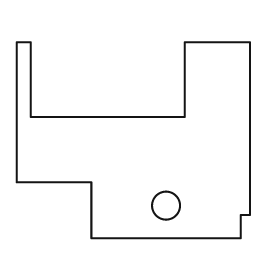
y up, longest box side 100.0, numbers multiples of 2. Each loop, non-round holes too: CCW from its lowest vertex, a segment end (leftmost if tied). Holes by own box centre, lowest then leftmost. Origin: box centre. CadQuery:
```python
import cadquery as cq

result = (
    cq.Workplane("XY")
    .moveTo(-18.0, -42.0)
    .lineTo(46.0, -42.0)
    .lineTo(46.0, -32.0)
    .lineTo(50.0, -32.0)
    .lineTo(50.0, 42.0)
    .lineTo(22.0, 42.0)
    .lineTo(22.0, 10.0)
    .lineTo(-44.0, 10.0)
    .lineTo(-44.0, 42.0)
    .lineTo(-50.0, 42.0)
    .lineTo(-50.0, -18.0)
    .lineTo(-18.0, -18.0)
    .close()
    .moveTo(14.0, -28.0)
    .circle(6.0)
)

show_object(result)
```